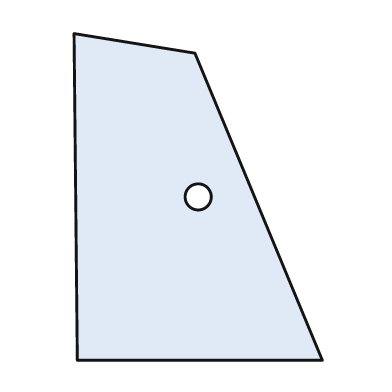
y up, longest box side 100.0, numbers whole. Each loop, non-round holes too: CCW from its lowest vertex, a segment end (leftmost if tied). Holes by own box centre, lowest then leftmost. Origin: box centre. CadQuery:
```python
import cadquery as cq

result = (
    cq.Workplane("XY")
    .moveTo(-37.0, -50.0)
    .lineTo(38.0, -50.0)
    .lineTo(-1.0, 44.0)
    .lineTo(-38.0, 50.0)
    .close()
    .moveTo(0.0, 0.0)
    .circle(4.0)
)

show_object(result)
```